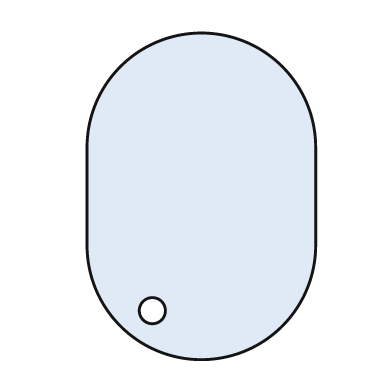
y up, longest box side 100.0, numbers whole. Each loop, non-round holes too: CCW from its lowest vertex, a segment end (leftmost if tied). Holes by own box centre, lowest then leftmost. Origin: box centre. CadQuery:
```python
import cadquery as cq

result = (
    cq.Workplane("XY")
    .moveTo(-35.0, -15.0)
    .threePointArc((0.0, -50.0), (35.0, -15.0))
    .lineTo(35.0, 15.0)
    .threePointArc((0.0, 50.0), (-35.0, 15.0))
    .close()
    .moveTo(-15.0, -35.0)
    .circle(4.0)
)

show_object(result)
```